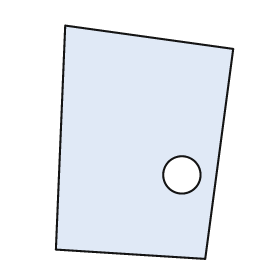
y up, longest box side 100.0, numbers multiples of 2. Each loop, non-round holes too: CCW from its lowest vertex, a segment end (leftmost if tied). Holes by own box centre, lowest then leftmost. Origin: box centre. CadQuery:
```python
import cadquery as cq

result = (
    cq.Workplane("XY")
    .moveTo(26.0, -50.0)
    .lineTo(38.0, 40.0)
    .lineTo(-34.0, 50.0)
    .lineTo(-38.0, -46.0)
    .close()
    .moveTo(16.0, -14.0)
    .circle(8.0)
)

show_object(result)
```